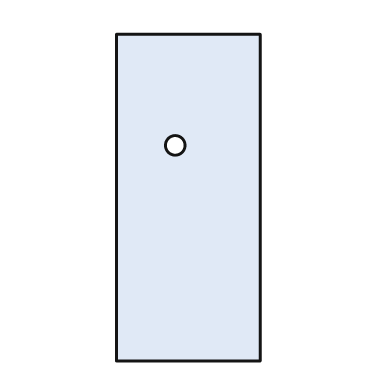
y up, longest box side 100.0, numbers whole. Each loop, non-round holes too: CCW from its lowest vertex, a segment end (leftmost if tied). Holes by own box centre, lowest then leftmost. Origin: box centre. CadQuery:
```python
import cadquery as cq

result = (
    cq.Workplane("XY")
    .moveTo(-22.0, -50.0)
    .lineTo(22.0, -50.0)
    .lineTo(22.0, 50.0)
    .lineTo(-22.0, 50.0)
    .close()
    .moveTo(-4.0, 16.0)
    .circle(3.0)
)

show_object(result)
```